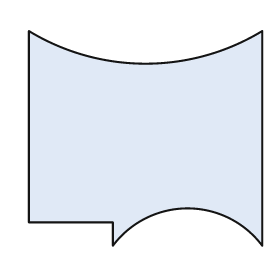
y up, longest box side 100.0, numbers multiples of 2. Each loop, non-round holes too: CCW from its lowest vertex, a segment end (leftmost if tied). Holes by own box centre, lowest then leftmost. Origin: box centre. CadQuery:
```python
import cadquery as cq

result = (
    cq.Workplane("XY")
    .moveTo(-14.0, -46.0)
    .threePointArc((18.0, -30.0), (50.0, -46.0))
    .lineTo(50.0, 46.0)
    .threePointArc((0.0, 32.0), (-50.0, 46.0))
    .lineTo(-50.0, -36.0)
    .lineTo(-14.0, -36.0)
    .close()
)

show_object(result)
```